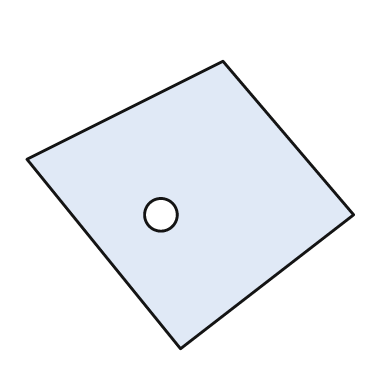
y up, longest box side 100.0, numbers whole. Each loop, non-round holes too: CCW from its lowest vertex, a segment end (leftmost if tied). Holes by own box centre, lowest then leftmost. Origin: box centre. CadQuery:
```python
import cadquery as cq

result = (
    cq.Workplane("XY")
    .moveTo(-3.0, -44.0)
    .lineTo(50.0, -3.0)
    .lineTo(10.0, 44.0)
    .lineTo(-50.0, 14.0)
    .close()
    .moveTo(-9.0, -3.0)
    .circle(5.0)
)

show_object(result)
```